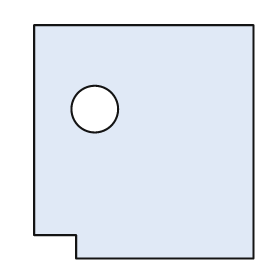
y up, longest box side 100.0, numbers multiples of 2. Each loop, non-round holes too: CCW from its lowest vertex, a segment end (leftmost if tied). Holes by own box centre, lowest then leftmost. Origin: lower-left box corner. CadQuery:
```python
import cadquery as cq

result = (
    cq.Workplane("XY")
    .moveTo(18.0, 0.0)
    .lineTo(94.0, 0.0)
    .lineTo(94.0, 100.0)
    .lineTo(0.0, 100.0)
    .lineTo(0.0, 10.0)
    .lineTo(18.0, 10.0)
    .close()
    .moveTo(26.0, 64.0)
    .circle(10.0)
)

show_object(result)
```